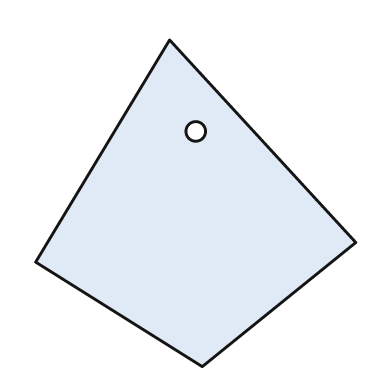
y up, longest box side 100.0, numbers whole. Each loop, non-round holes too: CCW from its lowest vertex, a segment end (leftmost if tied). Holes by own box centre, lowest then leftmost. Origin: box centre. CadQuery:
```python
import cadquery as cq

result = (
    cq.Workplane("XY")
    .moveTo(2.0, -50.0)
    .lineTo(49.0, -12.0)
    .lineTo(-8.0, 50.0)
    .lineTo(-49.0, -18.0)
    .close()
    .moveTo(0.0, 22.0)
    .circle(3.0)
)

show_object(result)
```